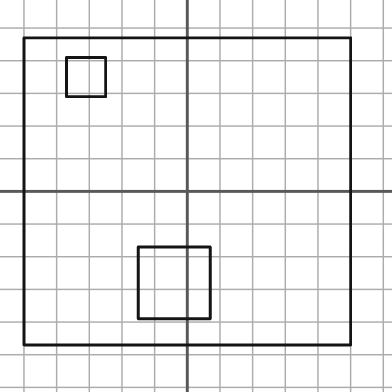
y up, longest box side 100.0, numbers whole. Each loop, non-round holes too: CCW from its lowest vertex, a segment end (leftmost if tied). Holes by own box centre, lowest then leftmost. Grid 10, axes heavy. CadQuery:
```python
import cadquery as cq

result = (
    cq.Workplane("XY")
    .moveTo(-50.0, -47.0)
    .lineTo(50.0, -47.0)
    .lineTo(50.0, 47.0)
    .lineTo(-50.0, 47.0)
    .close()
    .moveTo(-15.0, -39.0)
    .lineTo(7.0, -39.0)
    .lineTo(7.0, -17.0)
    .lineTo(-15.0, -17.0)
    .close()
    .moveTo(-37.0, 29.0)
    .lineTo(-25.0, 29.0)
    .lineTo(-25.0, 41.0)
    .lineTo(-37.0, 41.0)
    .close()
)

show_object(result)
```